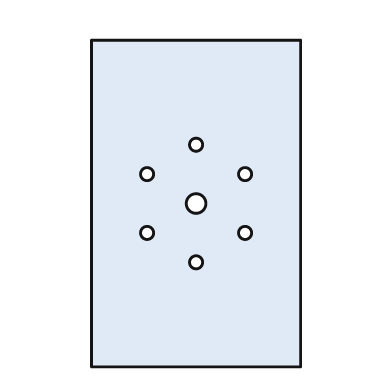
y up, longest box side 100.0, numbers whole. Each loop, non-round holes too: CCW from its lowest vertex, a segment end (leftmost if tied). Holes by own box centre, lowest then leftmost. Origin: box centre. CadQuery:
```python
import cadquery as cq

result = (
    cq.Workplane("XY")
    .moveTo(-32.0, -50.0)
    .lineTo(32.0, -50.0)
    .lineTo(32.0, 50.0)
    .lineTo(-32.0, 50.0)
    .close()
    .moveTo(0.0, -18.0)
    .circle(2.0)
    .moveTo(-15.0, -9.0)
    .circle(2.0)
    .moveTo(15.0, -9.0)
    .circle(2.0)
    .moveTo(0.0, 0.0)
    .circle(3.0)
    .moveTo(-15.0, 9.0)
    .circle(2.0)
    .moveTo(15.0, 9.0)
    .circle(2.0)
    .moveTo(0.0, 18.0)
    .circle(2.0)
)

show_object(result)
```